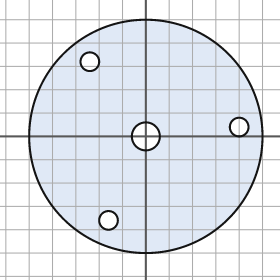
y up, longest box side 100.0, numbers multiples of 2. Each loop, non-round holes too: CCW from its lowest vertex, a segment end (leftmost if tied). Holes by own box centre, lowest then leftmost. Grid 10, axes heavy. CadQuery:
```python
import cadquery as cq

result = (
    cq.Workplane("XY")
    .moveTo(0.0, 0.0)
    .circle(50.0)
    .moveTo(-16.0, -36.0)
    .circle(4.0)
    .moveTo(0.0, 0.0)
    .circle(6.0)
    .moveTo(40.0, 4.0)
    .circle(4.0)
    .moveTo(-24.0, 32.0)
    .circle(4.0)
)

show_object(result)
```